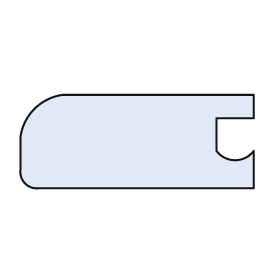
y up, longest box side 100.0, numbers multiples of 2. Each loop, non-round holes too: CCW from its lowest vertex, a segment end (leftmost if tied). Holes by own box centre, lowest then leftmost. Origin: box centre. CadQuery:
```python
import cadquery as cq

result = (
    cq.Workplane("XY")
    .moveTo(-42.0, -20.0)
    .lineTo(50.0, -20.0)
    .lineTo(50.0, -4.0)
    .threePointArc((42.0, -8.0), (34.0, -4.0))
    .lineTo(34.0, 10.0)
    .lineTo(50.0, 10.0)
    .lineTo(50.0, 20.0)
    .lineTo(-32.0, 20.0)
    .threePointArc((-44.0, 14.0), (-50.0, 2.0))
    .lineTo(-50.0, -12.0)
    .threePointArc((-48.0, -18.0), (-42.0, -20.0))
    .close()
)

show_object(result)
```